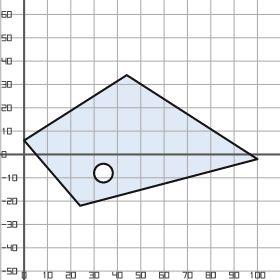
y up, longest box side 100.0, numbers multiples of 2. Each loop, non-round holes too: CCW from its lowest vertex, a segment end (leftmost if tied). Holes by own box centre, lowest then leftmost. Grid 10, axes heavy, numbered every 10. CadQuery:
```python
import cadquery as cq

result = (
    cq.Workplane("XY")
    .moveTo(24.0, -22.0)
    .lineTo(100.0, -2.0)
    .lineTo(44.0, 34.0)
    .lineTo(0.0, 6.0)
    .close()
    .moveTo(34.0, -8.0)
    .circle(4.0)
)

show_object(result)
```